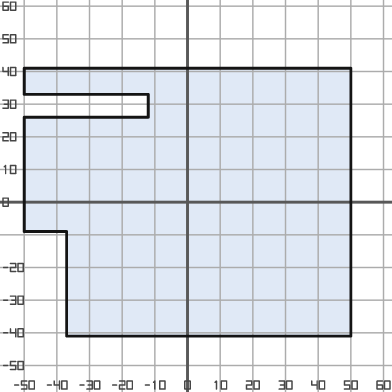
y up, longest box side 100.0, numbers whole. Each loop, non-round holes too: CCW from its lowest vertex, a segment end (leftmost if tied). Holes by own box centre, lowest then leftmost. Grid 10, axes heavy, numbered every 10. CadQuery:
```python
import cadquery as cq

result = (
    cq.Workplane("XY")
    .moveTo(-37.0, -41.0)
    .lineTo(50.0, -41.0)
    .lineTo(50.0, 41.0)
    .lineTo(-50.0, 41.0)
    .lineTo(-50.0, 33.0)
    .lineTo(-12.0, 33.0)
    .lineTo(-12.0, 26.0)
    .lineTo(-50.0, 26.0)
    .lineTo(-50.0, -9.0)
    .lineTo(-37.0, -9.0)
    .close()
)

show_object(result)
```